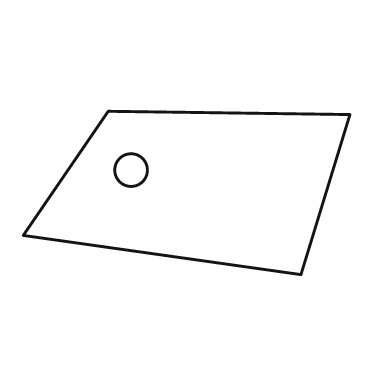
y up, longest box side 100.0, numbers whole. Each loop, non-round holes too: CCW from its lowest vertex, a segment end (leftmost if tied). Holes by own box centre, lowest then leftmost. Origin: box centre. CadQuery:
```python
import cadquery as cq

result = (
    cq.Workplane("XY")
    .moveTo(35.0, -25.0)
    .lineTo(50.0, 24.0)
    .lineTo(-24.0, 25.0)
    .lineTo(-50.0, -13.0)
    .close()
    .moveTo(-17.0, 7.0)
    .circle(5.0)
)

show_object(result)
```